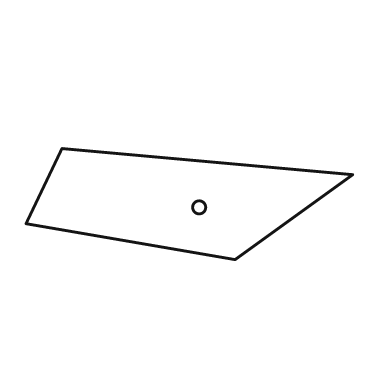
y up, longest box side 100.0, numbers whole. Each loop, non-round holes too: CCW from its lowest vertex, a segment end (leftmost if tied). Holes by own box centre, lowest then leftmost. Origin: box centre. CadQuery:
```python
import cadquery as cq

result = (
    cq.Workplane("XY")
    .moveTo(14.0, -17.0)
    .lineTo(50.0, 9.0)
    .lineTo(-39.0, 17.0)
    .lineTo(-50.0, -6.0)
    .close()
    .moveTo(3.0, -1.0)
    .circle(2.0)
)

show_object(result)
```